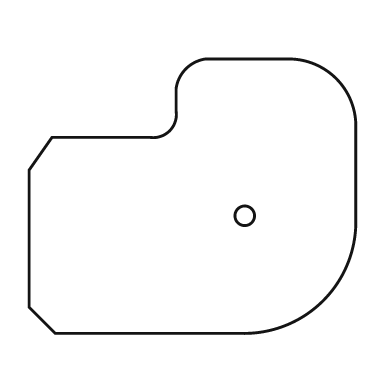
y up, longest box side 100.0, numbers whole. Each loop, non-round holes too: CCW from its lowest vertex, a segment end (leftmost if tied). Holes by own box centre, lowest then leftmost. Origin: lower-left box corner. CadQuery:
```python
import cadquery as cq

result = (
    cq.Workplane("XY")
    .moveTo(8.0, 0.0)
    .lineTo(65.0, 0.0)
    .threePointArc((90.0, 10.0), (100.0, 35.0))
    .lineTo(100.0, 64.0)
    .threePointArc((94.0, 78.0), (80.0, 84.0))
    .lineTo(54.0, 84.0)
    .threePointArc((48.0, 81.0), (45.0, 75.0))
    .lineTo(45.0, 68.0)
    .threePointArc((43.0, 62.0), (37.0, 60.0))
    .lineTo(7.0, 60.0)
    .lineTo(0.0, 50.0)
    .lineTo(0.0, 8.0)
    .close()
    .moveTo(66.0, 36.0)
    .circle(3.0)
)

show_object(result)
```